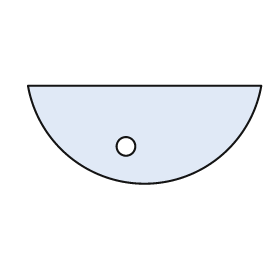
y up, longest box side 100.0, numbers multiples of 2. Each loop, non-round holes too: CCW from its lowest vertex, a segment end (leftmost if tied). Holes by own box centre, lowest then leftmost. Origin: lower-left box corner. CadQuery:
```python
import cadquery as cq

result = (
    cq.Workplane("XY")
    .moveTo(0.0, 42.0)
    .threePointArc((50.0, 0.0), (100.0, 42.0))
    .close()
    .moveTo(42.0, 16.0)
    .circle(4.0)
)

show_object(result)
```